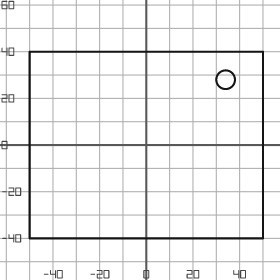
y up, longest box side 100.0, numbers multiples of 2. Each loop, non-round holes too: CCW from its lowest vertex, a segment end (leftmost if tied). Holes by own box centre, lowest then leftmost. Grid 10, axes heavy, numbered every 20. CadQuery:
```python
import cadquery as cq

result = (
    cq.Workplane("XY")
    .moveTo(-50.0, -40.0)
    .lineTo(50.0, -40.0)
    .lineTo(50.0, 40.0)
    .lineTo(-50.0, 40.0)
    .close()
    .moveTo(34.0, 28.0)
    .circle(4.0)
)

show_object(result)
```